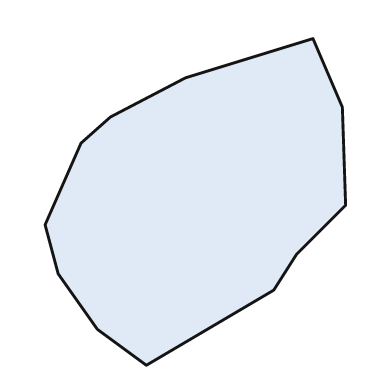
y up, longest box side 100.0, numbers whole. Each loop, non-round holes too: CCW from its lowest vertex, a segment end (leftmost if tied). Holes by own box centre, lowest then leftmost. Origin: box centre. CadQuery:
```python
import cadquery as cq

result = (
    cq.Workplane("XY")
    .moveTo(-15.0, -50.0)
    .lineTo(24.0, -27.0)
    .lineTo(31.0, -16.0)
    .lineTo(46.0, -1.0)
    .lineTo(45.0, 29.0)
    .lineTo(36.0, 50.0)
    .lineTo(-3.0, 38.0)
    .lineTo(-26.0, 26.0)
    .lineTo(-35.0, 18.0)
    .lineTo(-46.0, -7.0)
    .lineTo(-42.0, -22.0)
    .lineTo(-30.0, -39.0)
    .close()
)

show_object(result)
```